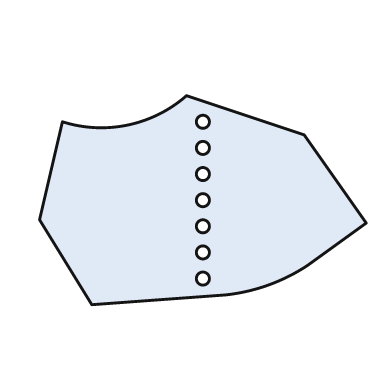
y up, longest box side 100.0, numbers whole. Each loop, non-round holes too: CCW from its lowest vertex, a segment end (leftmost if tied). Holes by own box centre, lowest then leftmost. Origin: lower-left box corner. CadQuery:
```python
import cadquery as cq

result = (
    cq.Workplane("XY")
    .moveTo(16.0, 0.0)
    .lineTo(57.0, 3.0)
    .threePointArc((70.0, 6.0), (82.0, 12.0))
    .lineTo(100.0, 25.0)
    .lineTo(81.0, 52.0)
    .lineTo(45.0, 64.0)
    .threePointArc((27.0, 55.0), (7.0, 56.0))
    .lineTo(0.0, 26.0)
    .close()
    .moveTo(50.0, 8.0)
    .circle(2.0)
    .moveTo(50.0, 16.0)
    .circle(2.0)
    .moveTo(50.0, 24.0)
    .circle(2.0)
    .moveTo(50.0, 32.0)
    .circle(2.0)
    .moveTo(50.0, 40.0)
    .circle(2.0)
    .moveTo(50.0, 48.0)
    .circle(2.0)
    .moveTo(50.0, 56.0)
    .circle(2.0)
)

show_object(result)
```